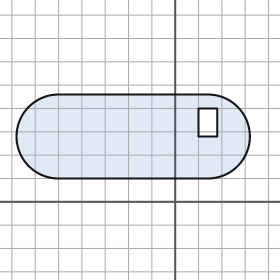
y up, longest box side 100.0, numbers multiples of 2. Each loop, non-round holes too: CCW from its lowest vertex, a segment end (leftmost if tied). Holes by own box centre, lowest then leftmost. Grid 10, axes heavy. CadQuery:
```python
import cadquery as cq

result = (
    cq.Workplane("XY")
    .moveTo(-50.0, 10.0)
    .lineTo(14.0, 10.0)
    .threePointArc((32.0, 28.0), (14.0, 46.0))
    .lineTo(-50.0, 46.0)
    .threePointArc((-68.0, 28.0), (-50.0, 10.0))
    .close()
    .moveTo(10.0, 28.0)
    .lineTo(18.0, 28.0)
    .lineTo(18.0, 40.0)
    .lineTo(10.0, 40.0)
    .close()
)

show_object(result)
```